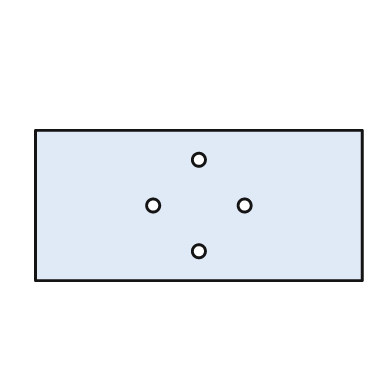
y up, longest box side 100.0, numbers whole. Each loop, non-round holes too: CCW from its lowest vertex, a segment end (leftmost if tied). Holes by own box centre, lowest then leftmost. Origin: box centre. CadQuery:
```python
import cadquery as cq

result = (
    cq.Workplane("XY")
    .moveTo(-50.0, -23.0)
    .lineTo(50.0, -23.0)
    .lineTo(50.0, 23.0)
    .lineTo(-50.0, 23.0)
    .close()
    .moveTo(0.0, -14.0)
    .circle(2.0)
    .moveTo(-14.0, 0.0)
    .circle(2.0)
    .moveTo(14.0, 0.0)
    .circle(2.0)
    .moveTo(0.0, 14.0)
    .circle(2.0)
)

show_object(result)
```